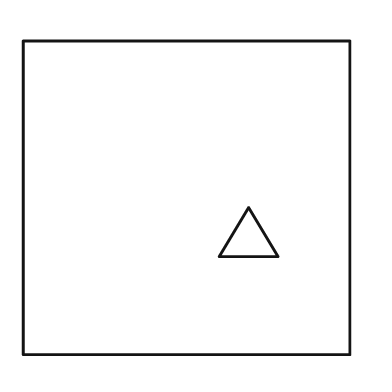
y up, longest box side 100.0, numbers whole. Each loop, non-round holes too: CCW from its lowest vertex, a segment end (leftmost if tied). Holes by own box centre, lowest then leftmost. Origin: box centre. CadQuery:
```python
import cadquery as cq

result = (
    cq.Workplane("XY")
    .moveTo(-50.0, -48.0)
    .lineTo(50.0, -48.0)
    .lineTo(50.0, 48.0)
    .lineTo(-50.0, 48.0)
    .close()
    .moveTo(10.0, -18.0)
    .lineTo(28.0, -18.0)
    .lineTo(19.0, -3.0)
    .close()
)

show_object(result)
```